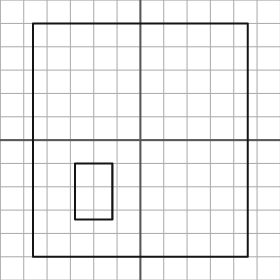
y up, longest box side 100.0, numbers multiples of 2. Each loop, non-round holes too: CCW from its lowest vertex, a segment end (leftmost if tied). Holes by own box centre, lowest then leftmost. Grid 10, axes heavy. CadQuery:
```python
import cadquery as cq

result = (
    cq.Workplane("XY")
    .moveTo(-46.0, -50.0)
    .lineTo(46.0, -50.0)
    .lineTo(46.0, 50.0)
    .lineTo(-46.0, 50.0)
    .close()
    .moveTo(-28.0, -34.0)
    .lineTo(-12.0, -34.0)
    .lineTo(-12.0, -10.0)
    .lineTo(-28.0, -10.0)
    .close()
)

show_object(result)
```